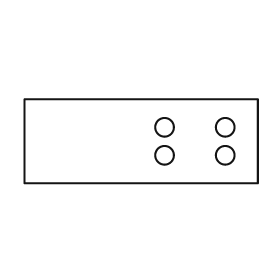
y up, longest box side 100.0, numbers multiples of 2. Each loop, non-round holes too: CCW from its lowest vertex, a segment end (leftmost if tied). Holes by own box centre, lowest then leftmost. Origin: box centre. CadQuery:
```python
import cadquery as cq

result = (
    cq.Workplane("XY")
    .moveTo(-50.0, -18.0)
    .lineTo(50.0, -18.0)
    .lineTo(50.0, 18.0)
    .lineTo(-50.0, 18.0)
    .close()
    .moveTo(10.0, -6.0)
    .circle(4.0)
    .moveTo(36.0, -6.0)
    .circle(4.0)
    .moveTo(10.0, 6.0)
    .circle(4.0)
    .moveTo(36.0, 6.0)
    .circle(4.0)
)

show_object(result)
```